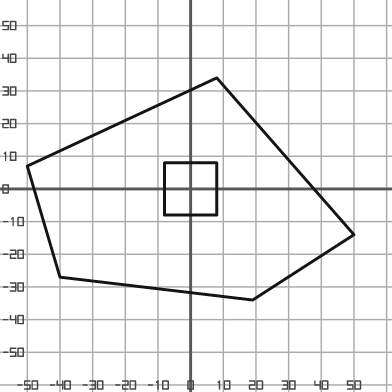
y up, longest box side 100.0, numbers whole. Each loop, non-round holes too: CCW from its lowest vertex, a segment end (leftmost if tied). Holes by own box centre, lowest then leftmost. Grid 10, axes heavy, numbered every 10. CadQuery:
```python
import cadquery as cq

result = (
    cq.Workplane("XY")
    .moveTo(19.0, -34.0)
    .lineTo(50.0, -14.0)
    .lineTo(8.0, 34.0)
    .lineTo(-50.0, 7.0)
    .lineTo(-40.0, -27.0)
    .close()
    .moveTo(-8.0, -8.0)
    .lineTo(8.0, -8.0)
    .lineTo(8.0, 8.0)
    .lineTo(-8.0, 8.0)
    .close()
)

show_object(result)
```